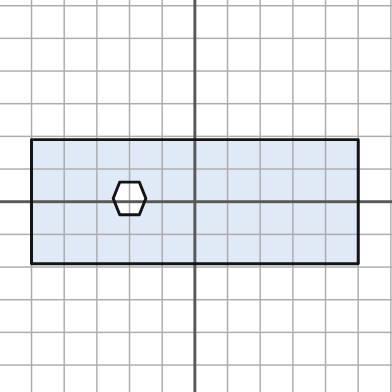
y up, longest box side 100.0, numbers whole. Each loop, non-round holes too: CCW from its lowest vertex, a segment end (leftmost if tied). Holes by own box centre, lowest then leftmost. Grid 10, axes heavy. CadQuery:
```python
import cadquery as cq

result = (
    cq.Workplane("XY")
    .moveTo(-50.0, -19.0)
    .lineTo(50.0, -19.0)
    .lineTo(50.0, 19.0)
    .lineTo(-50.0, 19.0)
    .close()
    .moveTo(-23.0, -4.0)
    .lineTo(-17.0, -4.0)
    .lineTo(-15.0, 1.0)
    .lineTo(-17.0, 6.0)
    .lineTo(-23.0, 6.0)
    .lineTo(-25.0, 1.0)
    .close()
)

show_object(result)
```